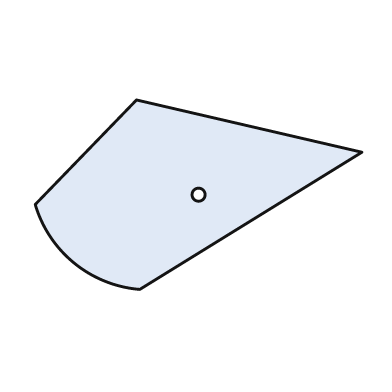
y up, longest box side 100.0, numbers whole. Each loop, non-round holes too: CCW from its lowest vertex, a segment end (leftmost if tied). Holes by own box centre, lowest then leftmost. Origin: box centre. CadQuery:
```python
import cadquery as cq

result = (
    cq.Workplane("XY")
    .moveTo(-18.0, -29.0)
    .lineTo(50.0, 13.0)
    .lineTo(-19.0, 29.0)
    .lineTo(-50.0, -3.0)
    .threePointArc((-38.0, -21.0), (-18.0, -29.0))
    .close()
    .moveTo(0.0, 0.0)
    .circle(2.0)
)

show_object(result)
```